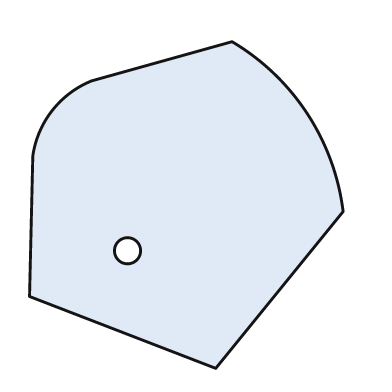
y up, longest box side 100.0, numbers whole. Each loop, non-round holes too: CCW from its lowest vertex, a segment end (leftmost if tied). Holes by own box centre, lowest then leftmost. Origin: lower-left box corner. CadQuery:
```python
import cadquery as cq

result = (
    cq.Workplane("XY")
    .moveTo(57.0, 0.0)
    .lineTo(96.0, 48.0)
    .threePointArc((85.0, 78.0), (62.0, 100.0))
    .lineTo(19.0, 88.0)
    .threePointArc((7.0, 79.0), (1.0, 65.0))
    .lineTo(0.0, 22.0)
    .close()
    .moveTo(30.0, 36.0)
    .circle(4.0)
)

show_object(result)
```